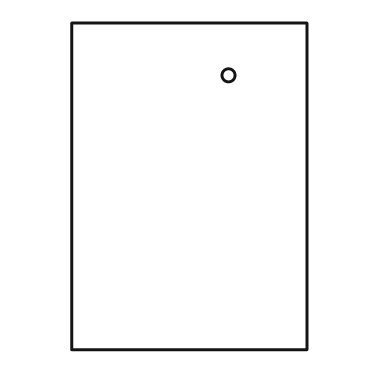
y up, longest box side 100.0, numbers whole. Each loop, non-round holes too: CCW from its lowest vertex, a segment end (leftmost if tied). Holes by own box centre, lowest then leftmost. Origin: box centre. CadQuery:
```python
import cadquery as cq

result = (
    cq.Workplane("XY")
    .moveTo(-36.0, -50.0)
    .lineTo(36.0, -50.0)
    .lineTo(36.0, 50.0)
    .lineTo(-36.0, 50.0)
    .close()
    .moveTo(12.0, 34.0)
    .circle(2.0)
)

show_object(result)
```